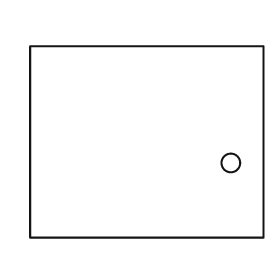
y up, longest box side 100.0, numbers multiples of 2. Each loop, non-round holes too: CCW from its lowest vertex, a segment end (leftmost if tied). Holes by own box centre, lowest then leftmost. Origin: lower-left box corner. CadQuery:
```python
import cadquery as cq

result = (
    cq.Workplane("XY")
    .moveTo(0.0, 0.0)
    .lineTo(100.0, 0.0)
    .lineTo(100.0, 82.0)
    .lineTo(0.0, 82.0)
    .close()
    .moveTo(86.0, 32.0)
    .circle(4.0)
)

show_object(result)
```